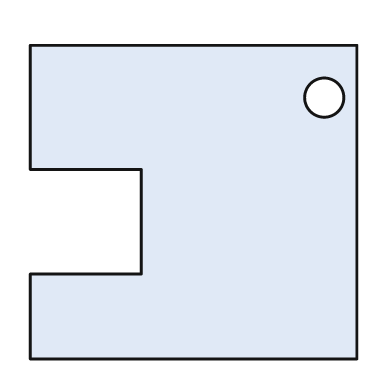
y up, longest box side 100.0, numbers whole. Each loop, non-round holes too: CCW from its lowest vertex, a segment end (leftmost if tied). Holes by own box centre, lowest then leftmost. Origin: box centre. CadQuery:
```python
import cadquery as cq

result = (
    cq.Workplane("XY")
    .moveTo(-50.0, -48.0)
    .lineTo(50.0, -48.0)
    .lineTo(50.0, 48.0)
    .lineTo(-50.0, 48.0)
    .lineTo(-50.0, 10.0)
    .lineTo(-16.0, 10.0)
    .lineTo(-16.0, -22.0)
    .lineTo(-50.0, -22.0)
    .close()
    .moveTo(40.0, 32.0)
    .circle(6.0)
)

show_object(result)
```